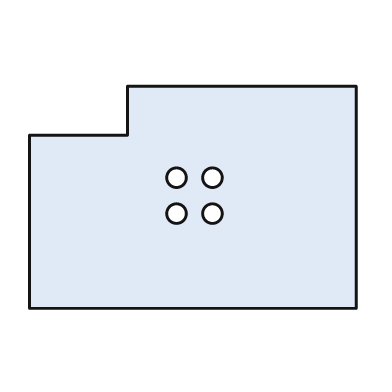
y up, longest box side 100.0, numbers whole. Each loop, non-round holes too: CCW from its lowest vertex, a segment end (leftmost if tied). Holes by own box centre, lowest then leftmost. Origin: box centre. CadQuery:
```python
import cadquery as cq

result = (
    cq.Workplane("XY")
    .moveTo(-50.0, -34.0)
    .lineTo(50.0, -34.0)
    .lineTo(50.0, 34.0)
    .lineTo(-20.0, 34.0)
    .lineTo(-20.0, 19.0)
    .lineTo(-50.0, 19.0)
    .close()
    .moveTo(-5.0, -5.0)
    .circle(3.0)
    .moveTo(6.0, -5.0)
    .circle(3.0)
    .moveTo(-5.0, 6.0)
    .circle(3.0)
    .moveTo(6.0, 6.0)
    .circle(3.0)
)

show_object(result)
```